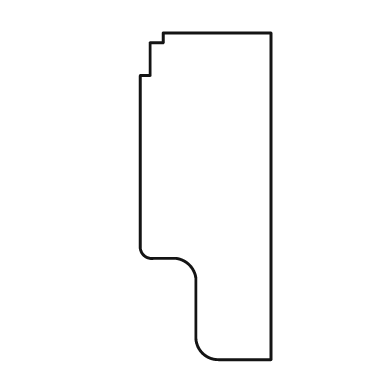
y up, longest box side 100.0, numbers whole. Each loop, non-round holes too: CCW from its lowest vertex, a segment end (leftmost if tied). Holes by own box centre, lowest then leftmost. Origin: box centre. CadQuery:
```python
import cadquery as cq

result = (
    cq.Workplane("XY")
    .moveTo(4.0, -50.0)
    .lineTo(20.0, -50.0)
    .lineTo(20.0, 50.0)
    .lineTo(-13.0, 50.0)
    .lineTo(-13.0, 47.0)
    .lineTo(-17.0, 47.0)
    .lineTo(-17.0, 37.0)
    .lineTo(-20.0, 37.0)
    .lineTo(-20.0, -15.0)
    .threePointArc((-19.0, -18.0), (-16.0, -19.0))
    .lineTo(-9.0, -19.0)
    .threePointArc((-5.0, -21.0), (-3.0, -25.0))
    .lineTo(-3.0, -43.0)
    .threePointArc((-1.0, -48.0), (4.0, -50.0))
    .close()
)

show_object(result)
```